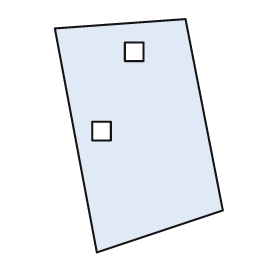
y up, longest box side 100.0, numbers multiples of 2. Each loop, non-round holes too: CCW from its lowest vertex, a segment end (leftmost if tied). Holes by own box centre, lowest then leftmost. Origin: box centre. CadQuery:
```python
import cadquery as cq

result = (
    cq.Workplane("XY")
    .moveTo(-18.0, -50.0)
    .lineTo(36.0, -32.0)
    .lineTo(20.0, 50.0)
    .lineTo(-36.0, 46.0)
    .close()
    .moveTo(-20.0, -2.0)
    .lineTo(-12.0, -2.0)
    .lineTo(-12.0, 6.0)
    .lineTo(-20.0, 6.0)
    .close()
    .moveTo(-6.0, 32.0)
    .lineTo(2.0, 32.0)
    .lineTo(2.0, 40.0)
    .lineTo(-6.0, 40.0)
    .close()
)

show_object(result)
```